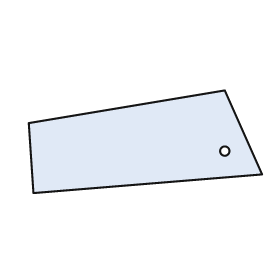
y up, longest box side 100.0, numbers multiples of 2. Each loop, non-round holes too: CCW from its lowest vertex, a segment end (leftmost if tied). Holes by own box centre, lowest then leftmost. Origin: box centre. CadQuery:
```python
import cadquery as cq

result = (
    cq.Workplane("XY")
    .moveTo(-48.0, -22.0)
    .lineTo(50.0, -14.0)
    .lineTo(34.0, 22.0)
    .lineTo(-50.0, 8.0)
    .close()
    .moveTo(34.0, -4.0)
    .circle(2.0)
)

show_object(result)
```